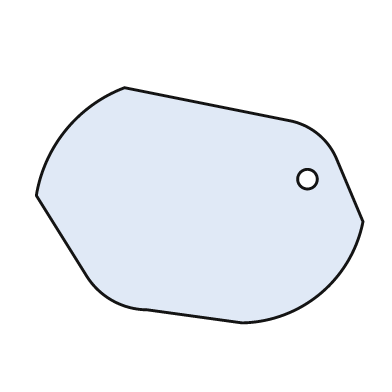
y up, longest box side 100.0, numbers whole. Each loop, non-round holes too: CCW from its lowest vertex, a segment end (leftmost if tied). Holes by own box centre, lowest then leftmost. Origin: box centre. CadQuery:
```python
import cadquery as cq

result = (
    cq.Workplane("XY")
    .moveTo(13.0, -36.0)
    .threePointArc((37.0, -27.0), (50.0, -5.0))
    .lineTo(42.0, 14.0)
    .threePointArc((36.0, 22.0), (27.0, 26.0))
    .lineTo(-23.0, 36.0)
    .threePointArc((-41.0, 23.0), (-50.0, 3.0))
    .lineTo(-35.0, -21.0)
    .threePointArc((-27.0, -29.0), (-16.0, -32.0))
    .close()
    .moveTo(33.0, 8.0)
    .circle(3.0)
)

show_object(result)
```